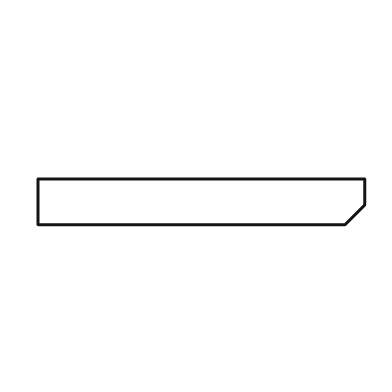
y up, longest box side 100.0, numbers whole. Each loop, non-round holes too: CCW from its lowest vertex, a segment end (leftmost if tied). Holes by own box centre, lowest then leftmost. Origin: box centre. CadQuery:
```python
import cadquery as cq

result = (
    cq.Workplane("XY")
    .moveTo(-50.0, -7.0)
    .lineTo(44.0, -7.0)
    .lineTo(50.0, -1.0)
    .lineTo(50.0, 7.0)
    .lineTo(-50.0, 7.0)
    .close()
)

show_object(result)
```